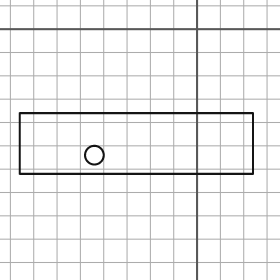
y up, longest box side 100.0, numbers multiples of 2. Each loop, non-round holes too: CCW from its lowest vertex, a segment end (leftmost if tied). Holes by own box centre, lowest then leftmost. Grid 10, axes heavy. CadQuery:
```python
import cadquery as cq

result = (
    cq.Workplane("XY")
    .moveTo(-76.0, -62.0)
    .lineTo(24.0, -62.0)
    .lineTo(24.0, -36.0)
    .lineTo(-76.0, -36.0)
    .close()
    .moveTo(-44.0, -54.0)
    .circle(4.0)
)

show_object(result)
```